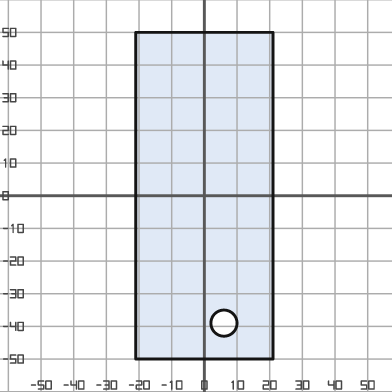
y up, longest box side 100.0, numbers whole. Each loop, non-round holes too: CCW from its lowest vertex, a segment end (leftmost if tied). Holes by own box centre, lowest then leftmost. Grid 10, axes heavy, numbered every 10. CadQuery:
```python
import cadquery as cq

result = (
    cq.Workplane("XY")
    .moveTo(-21.0, -50.0)
    .lineTo(21.0, -50.0)
    .lineTo(21.0, 50.0)
    .lineTo(-21.0, 50.0)
    .close()
    .moveTo(6.0, -39.0)
    .circle(4.0)
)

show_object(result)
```